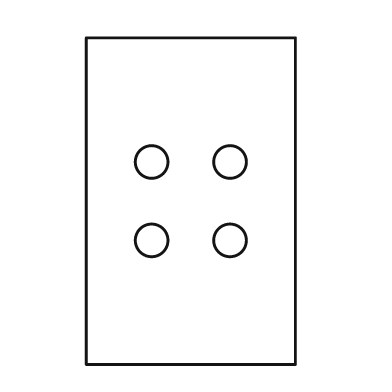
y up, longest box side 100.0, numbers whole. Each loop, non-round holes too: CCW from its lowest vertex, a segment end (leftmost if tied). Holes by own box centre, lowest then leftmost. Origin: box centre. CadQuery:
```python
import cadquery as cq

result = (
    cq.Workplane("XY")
    .moveTo(-32.0, -50.0)
    .lineTo(32.0, -50.0)
    .lineTo(32.0, 50.0)
    .lineTo(-32.0, 50.0)
    .close()
    .moveTo(-12.0, -12.0)
    .circle(5.0)
    .moveTo(12.0, -12.0)
    .circle(5.0)
    .moveTo(-12.0, 12.0)
    .circle(5.0)
    .moveTo(12.0, 12.0)
    .circle(5.0)
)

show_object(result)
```